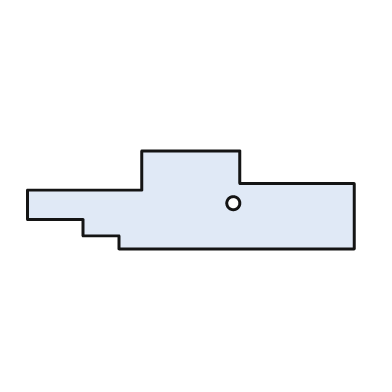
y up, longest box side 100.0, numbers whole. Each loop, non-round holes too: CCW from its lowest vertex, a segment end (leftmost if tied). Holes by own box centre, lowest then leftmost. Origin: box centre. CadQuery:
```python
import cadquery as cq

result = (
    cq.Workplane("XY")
    .moveTo(-22.0, -15.0)
    .lineTo(50.0, -15.0)
    .lineTo(50.0, 5.0)
    .lineTo(15.0, 5.0)
    .lineTo(15.0, 15.0)
    .lineTo(-15.0, 15.0)
    .lineTo(-15.0, 3.0)
    .lineTo(-50.0, 3.0)
    .lineTo(-50.0, -6.0)
    .lineTo(-33.0, -6.0)
    .lineTo(-33.0, -11.0)
    .lineTo(-22.0, -11.0)
    .close()
    .moveTo(13.0, -1.0)
    .circle(2.0)
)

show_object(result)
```